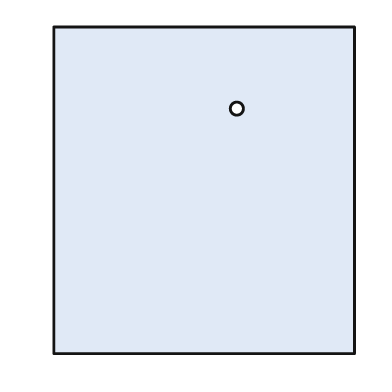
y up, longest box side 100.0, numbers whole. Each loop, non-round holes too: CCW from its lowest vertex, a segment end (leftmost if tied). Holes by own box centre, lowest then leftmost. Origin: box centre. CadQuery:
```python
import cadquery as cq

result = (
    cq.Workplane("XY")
    .moveTo(-46.0, -50.0)
    .lineTo(46.0, -50.0)
    .lineTo(46.0, 50.0)
    .lineTo(-46.0, 50.0)
    .close()
    .moveTo(10.0, 25.0)
    .circle(2.0)
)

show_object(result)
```